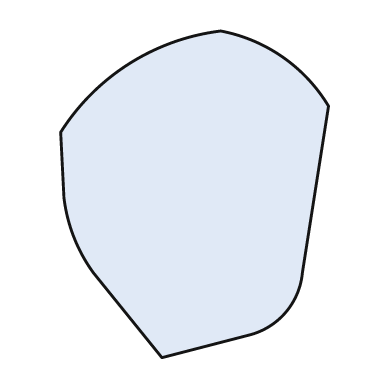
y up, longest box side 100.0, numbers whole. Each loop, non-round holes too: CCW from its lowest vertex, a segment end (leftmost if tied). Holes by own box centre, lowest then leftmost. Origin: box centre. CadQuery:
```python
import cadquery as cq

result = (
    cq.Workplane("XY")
    .moveTo(-10.0, -50.0)
    .lineTo(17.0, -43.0)
    .threePointArc((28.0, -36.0), (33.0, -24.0))
    .lineTo(41.0, 27.0)
    .threePointArc((27.0, 42.0), (8.0, 50.0))
    .threePointArc((-20.0, 40.0), (-41.0, 19.0))
    .lineTo(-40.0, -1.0)
    .threePointArc((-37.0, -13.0), (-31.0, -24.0))
    .close()
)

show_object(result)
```